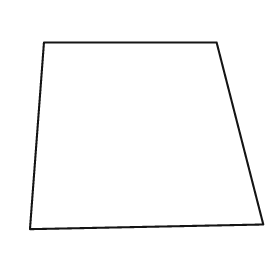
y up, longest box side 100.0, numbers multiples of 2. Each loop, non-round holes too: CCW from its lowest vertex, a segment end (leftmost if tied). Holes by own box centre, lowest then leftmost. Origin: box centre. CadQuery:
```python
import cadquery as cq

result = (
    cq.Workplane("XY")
    .moveTo(-50.0, -40.0)
    .lineTo(50.0, -38.0)
    .lineTo(30.0, 40.0)
    .lineTo(-44.0, 40.0)
    .close()
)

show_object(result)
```